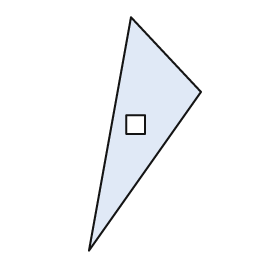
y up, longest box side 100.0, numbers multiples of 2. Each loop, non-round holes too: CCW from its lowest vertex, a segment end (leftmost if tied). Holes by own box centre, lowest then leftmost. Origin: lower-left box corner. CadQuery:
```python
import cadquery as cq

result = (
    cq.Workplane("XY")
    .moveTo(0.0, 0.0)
    .lineTo(48.0, 68.0)
    .lineTo(18.0, 100.0)
    .close()
    .moveTo(16.0, 50.0)
    .lineTo(24.0, 50.0)
    .lineTo(24.0, 58.0)
    .lineTo(16.0, 58.0)
    .close()
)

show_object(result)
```